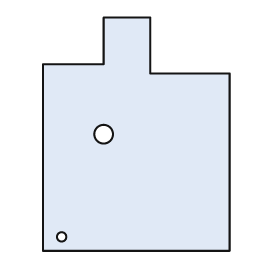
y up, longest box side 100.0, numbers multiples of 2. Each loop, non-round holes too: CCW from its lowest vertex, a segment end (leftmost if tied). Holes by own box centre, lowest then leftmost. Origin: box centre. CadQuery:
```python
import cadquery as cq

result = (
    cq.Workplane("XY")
    .moveTo(-40.0, -50.0)
    .lineTo(40.0, -50.0)
    .lineTo(40.0, 26.0)
    .lineTo(6.0, 26.0)
    .lineTo(6.0, 50.0)
    .lineTo(-14.0, 50.0)
    .lineTo(-14.0, 30.0)
    .lineTo(-40.0, 30.0)
    .close()
    .moveTo(-32.0, -44.0)
    .circle(2.0)
    .moveTo(-14.0, 0.0)
    .circle(4.0)
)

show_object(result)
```